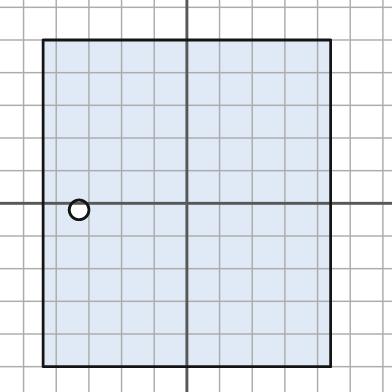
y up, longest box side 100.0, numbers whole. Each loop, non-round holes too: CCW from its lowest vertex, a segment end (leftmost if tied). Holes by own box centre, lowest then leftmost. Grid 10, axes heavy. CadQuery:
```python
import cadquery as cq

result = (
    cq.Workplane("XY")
    .moveTo(-44.0, -50.0)
    .lineTo(44.0, -50.0)
    .lineTo(44.0, 50.0)
    .lineTo(-44.0, 50.0)
    .close()
    .moveTo(-33.0, -2.0)
    .circle(3.0)
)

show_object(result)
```